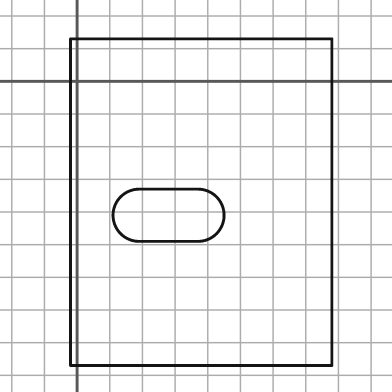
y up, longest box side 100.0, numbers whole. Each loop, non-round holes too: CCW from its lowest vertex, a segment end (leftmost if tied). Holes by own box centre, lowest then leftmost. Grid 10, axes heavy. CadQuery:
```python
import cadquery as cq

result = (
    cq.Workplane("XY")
    .moveTo(-2.0, -87.0)
    .lineTo(78.0, -87.0)
    .lineTo(78.0, 13.0)
    .lineTo(-2.0, 13.0)
    .close()
    .moveTo(19.0, -49.0)
    .lineTo(37.0, -49.0)
    .threePointArc((45.0, -41.0), (37.0, -33.0))
    .lineTo(19.0, -33.0)
    .threePointArc((11.0, -41.0), (19.0, -49.0))
    .close()
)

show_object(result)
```